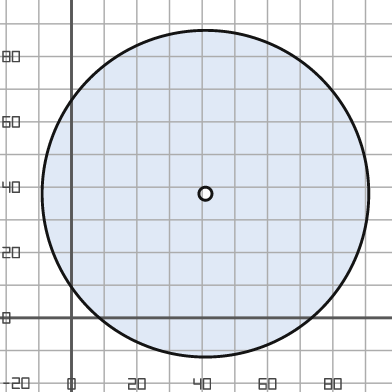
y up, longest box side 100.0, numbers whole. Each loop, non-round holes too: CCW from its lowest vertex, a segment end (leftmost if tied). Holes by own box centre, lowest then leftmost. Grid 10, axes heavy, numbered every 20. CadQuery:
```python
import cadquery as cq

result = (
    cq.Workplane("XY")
    .moveTo(41.0, 38.0)
    .circle(50.0)
    .moveTo(41.0, 38.0)
    .circle(2.0)
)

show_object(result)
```